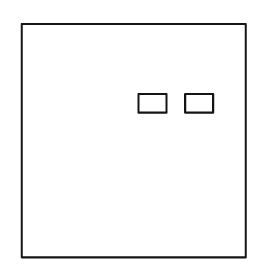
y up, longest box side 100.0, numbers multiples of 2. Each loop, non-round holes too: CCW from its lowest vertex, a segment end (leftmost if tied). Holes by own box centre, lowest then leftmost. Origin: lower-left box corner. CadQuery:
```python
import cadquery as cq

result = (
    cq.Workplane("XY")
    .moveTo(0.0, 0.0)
    .lineTo(96.0, 0.0)
    .lineTo(96.0, 100.0)
    .lineTo(0.0, 100.0)
    .close()
    .moveTo(50.0, 62.0)
    .lineTo(62.0, 62.0)
    .lineTo(62.0, 70.0)
    .lineTo(50.0, 70.0)
    .close()
    .moveTo(70.0, 62.0)
    .lineTo(82.0, 62.0)
    .lineTo(82.0, 70.0)
    .lineTo(70.0, 70.0)
    .close()
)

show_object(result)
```